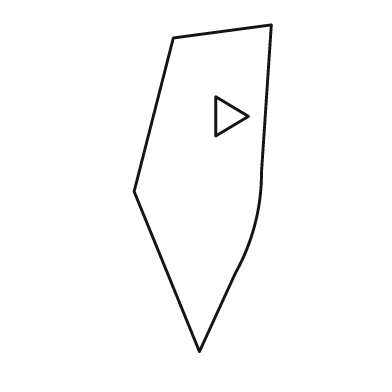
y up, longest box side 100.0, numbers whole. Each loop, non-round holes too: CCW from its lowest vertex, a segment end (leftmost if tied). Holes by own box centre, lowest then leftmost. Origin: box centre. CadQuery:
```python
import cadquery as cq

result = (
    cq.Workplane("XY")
    .moveTo(-1.0, -50.0)
    .lineTo(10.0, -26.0)
    .threePointArc((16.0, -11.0), (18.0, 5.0))
    .lineTo(21.0, 50.0)
    .lineTo(-9.0, 46.0)
    .lineTo(-21.0, -1.0)
    .close()
    .moveTo(4.0, 16.0)
    .lineTo(14.0, 22.0)
    .lineTo(4.0, 28.0)
    .close()
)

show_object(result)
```